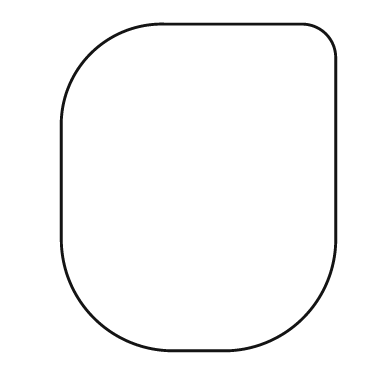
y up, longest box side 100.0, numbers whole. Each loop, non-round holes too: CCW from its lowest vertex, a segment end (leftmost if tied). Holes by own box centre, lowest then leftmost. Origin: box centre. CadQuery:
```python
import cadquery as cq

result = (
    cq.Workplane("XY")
    .moveTo(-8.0, -50.0)
    .lineTo(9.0, -50.0)
    .threePointArc((32.0, -40.0), (42.0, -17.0))
    .lineTo(42.0, 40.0)
    .threePointArc((39.0, 47.0), (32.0, 50.0))
    .lineTo(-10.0, 50.0)
    .threePointArc((-33.0, 41.0), (-42.0, 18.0))
    .lineTo(-42.0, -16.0)
    .threePointArc((-32.0, -40.0), (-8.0, -50.0))
    .close()
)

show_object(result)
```